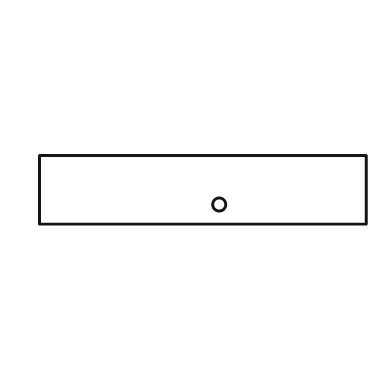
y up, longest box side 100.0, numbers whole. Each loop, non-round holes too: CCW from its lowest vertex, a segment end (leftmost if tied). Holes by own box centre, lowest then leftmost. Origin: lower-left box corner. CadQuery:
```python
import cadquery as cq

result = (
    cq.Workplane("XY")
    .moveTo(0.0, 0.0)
    .lineTo(100.0, 0.0)
    .lineTo(100.0, 21.0)
    .lineTo(0.0, 21.0)
    .close()
    .moveTo(55.0, 6.0)
    .circle(2.0)
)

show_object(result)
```